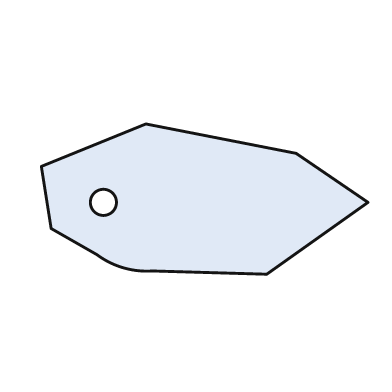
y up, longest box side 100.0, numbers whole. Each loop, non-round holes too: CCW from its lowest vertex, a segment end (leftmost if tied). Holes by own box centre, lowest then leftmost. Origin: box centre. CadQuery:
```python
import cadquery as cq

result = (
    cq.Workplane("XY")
    .moveTo(19.0, -23.0)
    .lineTo(50.0, -1.0)
    .lineTo(28.0, 14.0)
    .lineTo(-18.0, 23.0)
    .lineTo(-50.0, 10.0)
    .lineTo(-47.0, -9.0)
    .lineTo(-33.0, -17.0)
    .threePointArc((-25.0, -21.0), (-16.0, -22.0))
    .close()
    .moveTo(-31.0, -1.0)
    .circle(4.0)
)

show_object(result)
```